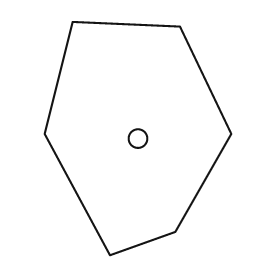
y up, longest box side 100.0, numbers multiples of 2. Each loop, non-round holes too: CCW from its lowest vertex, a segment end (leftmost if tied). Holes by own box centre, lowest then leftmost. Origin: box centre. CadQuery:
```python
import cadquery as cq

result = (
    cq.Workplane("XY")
    .moveTo(-12.0, -50.0)
    .lineTo(16.0, -40.0)
    .lineTo(40.0, 2.0)
    .lineTo(18.0, 48.0)
    .lineTo(-28.0, 50.0)
    .lineTo(-40.0, 2.0)
    .close()
    .moveTo(0.0, 0.0)
    .circle(4.0)
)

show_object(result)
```